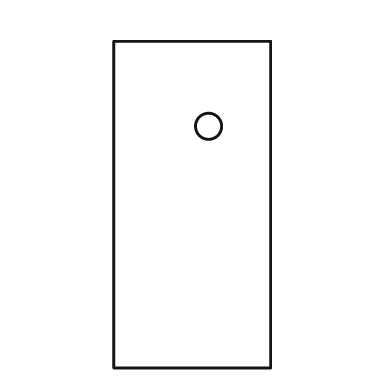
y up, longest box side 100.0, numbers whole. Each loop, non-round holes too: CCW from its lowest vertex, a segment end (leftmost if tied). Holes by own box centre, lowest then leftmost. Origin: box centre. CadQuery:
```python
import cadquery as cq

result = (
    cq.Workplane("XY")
    .moveTo(-24.0, -50.0)
    .lineTo(24.0, -50.0)
    .lineTo(24.0, 50.0)
    .lineTo(-24.0, 50.0)
    .close()
    .moveTo(5.0, 24.0)
    .circle(4.0)
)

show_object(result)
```